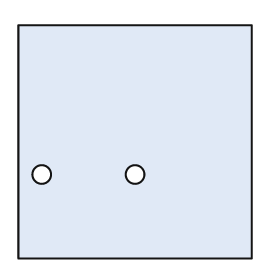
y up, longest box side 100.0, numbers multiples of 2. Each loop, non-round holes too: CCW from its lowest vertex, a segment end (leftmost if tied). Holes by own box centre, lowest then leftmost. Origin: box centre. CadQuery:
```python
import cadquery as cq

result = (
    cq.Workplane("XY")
    .moveTo(-50.0, -50.0)
    .lineTo(50.0, -50.0)
    .lineTo(50.0, 50.0)
    .lineTo(-50.0, 50.0)
    .close()
    .moveTo(-40.0, -14.0)
    .circle(4.0)
    .moveTo(0.0, -14.0)
    .circle(4.0)
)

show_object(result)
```